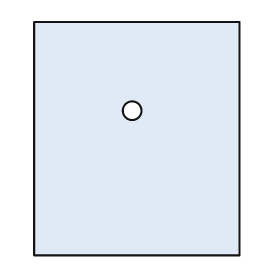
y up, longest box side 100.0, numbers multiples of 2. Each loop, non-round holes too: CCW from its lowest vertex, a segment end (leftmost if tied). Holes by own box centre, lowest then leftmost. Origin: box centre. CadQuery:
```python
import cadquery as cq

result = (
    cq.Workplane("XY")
    .moveTo(-44.0, -50.0)
    .lineTo(44.0, -50.0)
    .lineTo(44.0, 50.0)
    .lineTo(-44.0, 50.0)
    .close()
    .moveTo(-2.0, 12.0)
    .circle(4.0)
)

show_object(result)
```